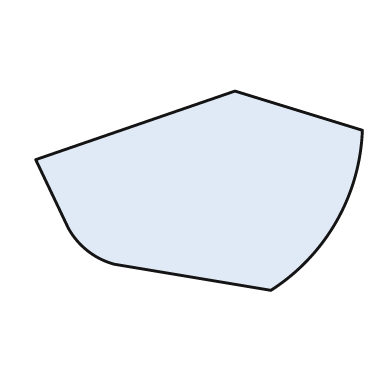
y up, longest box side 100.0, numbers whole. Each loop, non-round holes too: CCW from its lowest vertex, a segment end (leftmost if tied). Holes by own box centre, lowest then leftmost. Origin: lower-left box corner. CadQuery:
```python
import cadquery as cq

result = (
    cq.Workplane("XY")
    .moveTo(72.0, 0.0)
    .threePointArc((92.0, 21.0), (100.0, 49.0))
    .lineTo(61.0, 61.0)
    .lineTo(0.0, 40.0)
    .lineTo(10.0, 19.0)
    .threePointArc((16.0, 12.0), (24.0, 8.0))
    .close()
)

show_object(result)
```